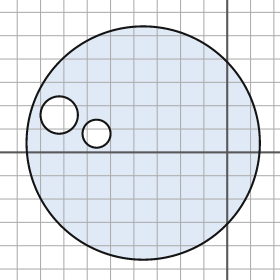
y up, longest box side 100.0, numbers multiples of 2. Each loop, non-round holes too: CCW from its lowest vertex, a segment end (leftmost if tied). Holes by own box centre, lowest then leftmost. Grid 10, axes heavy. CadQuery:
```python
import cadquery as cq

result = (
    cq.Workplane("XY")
    .moveTo(-36.0, 4.0)
    .circle(50.0)
    .moveTo(-56.0, 8.0)
    .circle(6.0)
    .moveTo(-72.0, 16.0)
    .circle(8.0)
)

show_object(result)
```